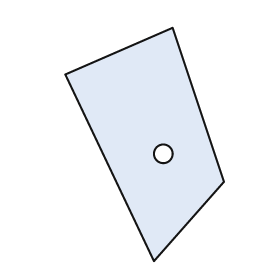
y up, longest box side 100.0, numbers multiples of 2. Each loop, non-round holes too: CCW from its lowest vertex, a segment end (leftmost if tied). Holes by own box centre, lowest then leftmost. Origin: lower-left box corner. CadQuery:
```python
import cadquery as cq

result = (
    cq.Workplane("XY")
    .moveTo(38.0, 0.0)
    .lineTo(68.0, 34.0)
    .lineTo(46.0, 100.0)
    .lineTo(0.0, 80.0)
    .close()
    .moveTo(42.0, 46.0)
    .circle(4.0)
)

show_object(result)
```